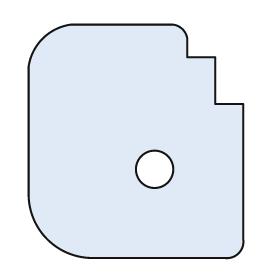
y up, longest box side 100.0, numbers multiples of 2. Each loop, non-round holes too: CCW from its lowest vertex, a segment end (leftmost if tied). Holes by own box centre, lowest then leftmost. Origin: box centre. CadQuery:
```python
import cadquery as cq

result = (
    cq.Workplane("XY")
    .moveTo(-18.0, -50.0)
    .lineTo(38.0, -50.0)
    .threePointArc((44.0, -48.0), (46.0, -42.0))
    .lineTo(46.0, 16.0)
    .lineTo(34.0, 16.0)
    .lineTo(34.0, 36.0)
    .lineTo(22.0, 36.0)
    .lineTo(22.0, 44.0)
    .threePointArc((20.0, 48.0), (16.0, 50.0))
    .lineTo(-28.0, 50.0)
    .threePointArc((-40.0, 44.0), (-46.0, 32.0))
    .lineTo(-46.0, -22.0)
    .threePointArc((-38.0, -42.0), (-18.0, -50.0))
    .close()
    .moveTo(8.0, -12.0)
    .circle(8.0)
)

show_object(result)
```